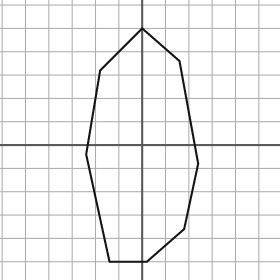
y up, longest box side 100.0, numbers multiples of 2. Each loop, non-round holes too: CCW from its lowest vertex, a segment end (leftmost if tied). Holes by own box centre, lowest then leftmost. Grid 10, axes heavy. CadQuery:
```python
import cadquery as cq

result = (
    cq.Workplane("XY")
    .moveTo(-14.0, -50.0)
    .lineTo(2.0, -50.0)
    .lineTo(18.0, -36.0)
    .lineTo(24.0, -8.0)
    .lineTo(16.0, 36.0)
    .lineTo(0.0, 50.0)
    .lineTo(-18.0, 32.0)
    .lineTo(-24.0, -4.0)
    .close()
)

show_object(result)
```